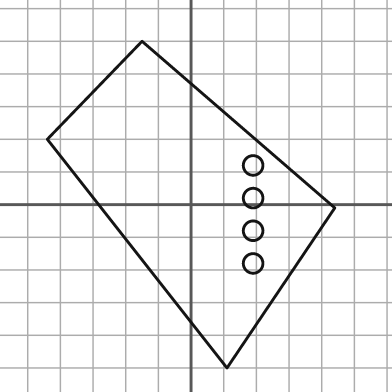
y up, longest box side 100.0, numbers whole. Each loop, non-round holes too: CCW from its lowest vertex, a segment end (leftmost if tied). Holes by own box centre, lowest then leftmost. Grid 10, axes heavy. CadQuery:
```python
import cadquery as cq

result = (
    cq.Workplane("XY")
    .moveTo(11.0, -50.0)
    .lineTo(44.0, -1.0)
    .lineTo(-15.0, 50.0)
    .lineTo(-44.0, 20.0)
    .close()
    .moveTo(19.0, -18.0)
    .circle(3.0)
    .moveTo(19.0, -8.0)
    .circle(3.0)
    .moveTo(19.0, 2.0)
    .circle(3.0)
    .moveTo(19.0, 12.0)
    .circle(3.0)
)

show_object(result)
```